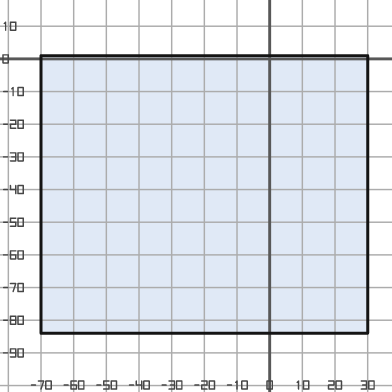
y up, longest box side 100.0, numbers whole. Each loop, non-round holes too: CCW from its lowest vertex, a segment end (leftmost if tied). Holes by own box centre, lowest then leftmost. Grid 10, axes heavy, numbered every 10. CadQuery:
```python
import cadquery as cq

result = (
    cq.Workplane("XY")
    .moveTo(-70.0, -84.0)
    .lineTo(30.0, -84.0)
    .lineTo(30.0, 1.0)
    .lineTo(-70.0, 1.0)
    .close()
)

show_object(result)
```